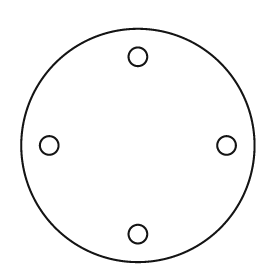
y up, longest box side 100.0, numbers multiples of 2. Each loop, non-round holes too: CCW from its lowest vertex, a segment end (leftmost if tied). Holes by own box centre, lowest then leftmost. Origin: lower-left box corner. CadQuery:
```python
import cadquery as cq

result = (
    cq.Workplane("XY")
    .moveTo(50.0, 50.0)
    .circle(50.0)
    .moveTo(50.0, 12.0)
    .circle(4.0)
    .moveTo(12.0, 50.0)
    .circle(4.0)
    .moveTo(88.0, 50.0)
    .circle(4.0)
    .moveTo(50.0, 88.0)
    .circle(4.0)
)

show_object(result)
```